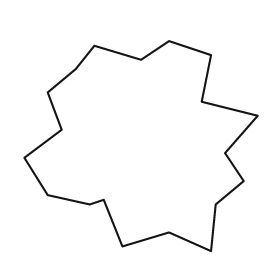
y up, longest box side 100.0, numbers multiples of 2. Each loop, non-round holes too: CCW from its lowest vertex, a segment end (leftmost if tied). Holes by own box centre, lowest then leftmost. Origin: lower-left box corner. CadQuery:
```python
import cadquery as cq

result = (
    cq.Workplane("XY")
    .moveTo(80.0, 0.0)
    .lineTo(82.0, 20.0)
    .lineTo(94.0, 30.0)
    .lineTo(86.0, 42.0)
    .lineTo(100.0, 58.0)
    .lineTo(76.0, 64.0)
    .lineTo(80.0, 84.0)
    .lineTo(62.0, 90.0)
    .lineTo(50.0, 82.0)
    .lineTo(30.0, 88.0)
    .lineTo(22.0, 78.0)
    .lineTo(10.0, 68.0)
    .lineTo(16.0, 52.0)
    .lineTo(0.0, 40.0)
    .lineTo(10.0, 24.0)
    .lineTo(28.0, 20.0)
    .lineTo(34.0, 22.0)
    .lineTo(42.0, 2.0)
    .lineTo(62.0, 8.0)
    .close()
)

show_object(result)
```